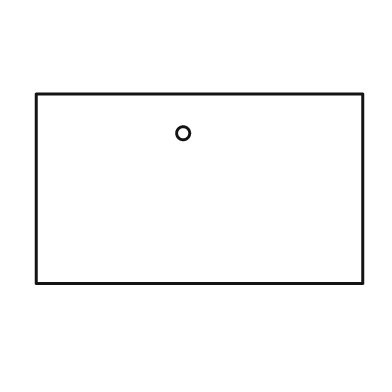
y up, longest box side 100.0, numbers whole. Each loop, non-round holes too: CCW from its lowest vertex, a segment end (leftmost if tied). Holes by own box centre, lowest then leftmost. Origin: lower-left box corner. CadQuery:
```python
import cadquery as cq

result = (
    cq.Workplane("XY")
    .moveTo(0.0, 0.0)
    .lineTo(100.0, 0.0)
    .lineTo(100.0, 58.0)
    .lineTo(0.0, 58.0)
    .close()
    .moveTo(45.0, 46.0)
    .circle(2.0)
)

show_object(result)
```